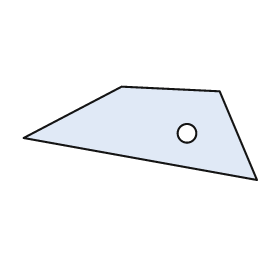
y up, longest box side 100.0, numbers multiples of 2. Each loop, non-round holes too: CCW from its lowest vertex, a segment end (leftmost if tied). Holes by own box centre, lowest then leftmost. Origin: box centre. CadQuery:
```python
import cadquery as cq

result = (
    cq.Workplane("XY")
    .moveTo(50.0, -20.0)
    .lineTo(34.0, 18.0)
    .lineTo(-8.0, 20.0)
    .lineTo(-50.0, -2.0)
    .close()
    .moveTo(20.0, 0.0)
    .circle(4.0)
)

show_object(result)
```